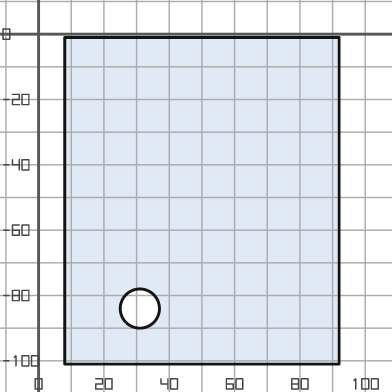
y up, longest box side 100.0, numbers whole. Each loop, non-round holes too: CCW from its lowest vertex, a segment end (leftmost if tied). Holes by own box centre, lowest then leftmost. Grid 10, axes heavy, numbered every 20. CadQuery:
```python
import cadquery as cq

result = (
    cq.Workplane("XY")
    .moveTo(8.0, -101.0)
    .lineTo(92.0, -101.0)
    .lineTo(92.0, -1.0)
    .lineTo(8.0, -1.0)
    .close()
    .moveTo(31.0, -84.0)
    .circle(6.0)
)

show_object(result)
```